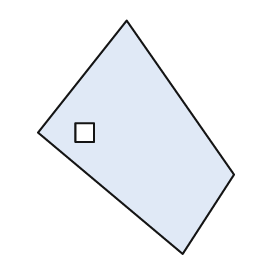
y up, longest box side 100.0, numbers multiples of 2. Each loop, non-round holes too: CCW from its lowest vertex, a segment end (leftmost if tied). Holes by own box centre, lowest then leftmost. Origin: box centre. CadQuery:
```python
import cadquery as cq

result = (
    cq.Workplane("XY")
    .moveTo(20.0, -50.0)
    .lineTo(42.0, -16.0)
    .lineTo(-4.0, 50.0)
    .lineTo(-42.0, 2.0)
    .close()
    .moveTo(-26.0, -2.0)
    .lineTo(-18.0, -2.0)
    .lineTo(-18.0, 6.0)
    .lineTo(-26.0, 6.0)
    .close()
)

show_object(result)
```